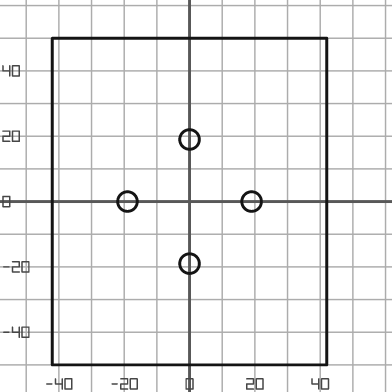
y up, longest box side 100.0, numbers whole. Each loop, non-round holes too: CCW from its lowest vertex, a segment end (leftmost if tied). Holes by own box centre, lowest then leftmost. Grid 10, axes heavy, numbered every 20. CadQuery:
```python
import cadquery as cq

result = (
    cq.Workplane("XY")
    .moveTo(-42.0, -50.0)
    .lineTo(42.0, -50.0)
    .lineTo(42.0, 50.0)
    .lineTo(-42.0, 50.0)
    .close()
    .moveTo(0.0, -19.0)
    .circle(3.0)
    .moveTo(-19.0, 0.0)
    .circle(3.0)
    .moveTo(19.0, 0.0)
    .circle(3.0)
    .moveTo(0.0, 19.0)
    .circle(3.0)
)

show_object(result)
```